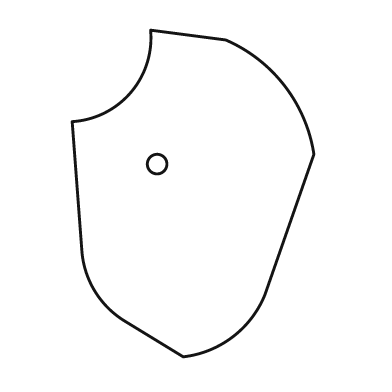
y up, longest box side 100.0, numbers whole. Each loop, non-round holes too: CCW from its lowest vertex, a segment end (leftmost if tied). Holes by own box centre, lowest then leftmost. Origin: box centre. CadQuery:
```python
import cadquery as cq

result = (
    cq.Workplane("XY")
    .moveTo(-3.0, -50.0)
    .threePointArc((12.0, -44.0), (22.0, -31.0))
    .lineTo(37.0, 12.0)
    .threePointArc((28.0, 33.0), (10.0, 47.0))
    .lineTo(-13.0, 50.0)
    .threePointArc((-19.0, 31.0), (-37.0, 22.0))
    .lineTo(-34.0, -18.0)
    .threePointArc((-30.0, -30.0), (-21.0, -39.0))
    .close()
    .moveTo(-11.0, 9.0)
    .circle(3.0)
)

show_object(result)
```